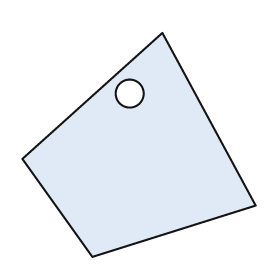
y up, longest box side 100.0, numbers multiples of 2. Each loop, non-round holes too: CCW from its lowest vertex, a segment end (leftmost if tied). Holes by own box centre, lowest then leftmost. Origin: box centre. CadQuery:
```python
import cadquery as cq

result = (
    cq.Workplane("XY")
    .moveTo(-20.0, -48.0)
    .lineTo(50.0, -26.0)
    .lineTo(10.0, 48.0)
    .lineTo(-50.0, -6.0)
    .close()
    .moveTo(-4.0, 22.0)
    .circle(6.0)
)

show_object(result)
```